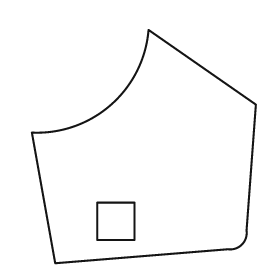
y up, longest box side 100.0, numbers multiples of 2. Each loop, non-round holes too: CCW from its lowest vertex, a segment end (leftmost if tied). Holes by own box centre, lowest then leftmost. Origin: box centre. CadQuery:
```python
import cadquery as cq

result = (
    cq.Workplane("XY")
    .moveTo(-38.0, -50.0)
    .lineTo(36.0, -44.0)
    .threePointArc((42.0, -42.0), (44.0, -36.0))
    .lineTo(48.0, 18.0)
    .lineTo(2.0, 50.0)
    .threePointArc((-14.0, 18.0), (-48.0, 6.0))
    .close()
    .moveTo(-20.0, -40.0)
    .lineTo(-4.0, -40.0)
    .lineTo(-4.0, -24.0)
    .lineTo(-20.0, -24.0)
    .close()
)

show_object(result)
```